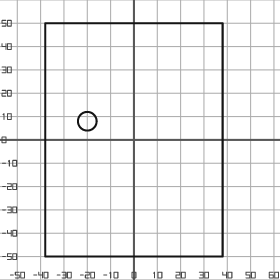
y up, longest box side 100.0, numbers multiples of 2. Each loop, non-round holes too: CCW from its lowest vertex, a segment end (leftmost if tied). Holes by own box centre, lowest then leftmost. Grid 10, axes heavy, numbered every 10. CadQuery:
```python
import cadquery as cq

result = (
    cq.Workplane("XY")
    .moveTo(-38.0, -50.0)
    .lineTo(38.0, -50.0)
    .lineTo(38.0, 50.0)
    .lineTo(-38.0, 50.0)
    .close()
    .moveTo(-20.0, 8.0)
    .circle(4.0)
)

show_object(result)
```